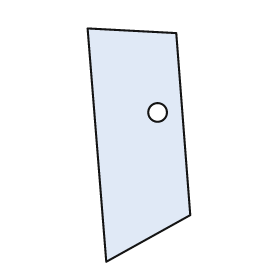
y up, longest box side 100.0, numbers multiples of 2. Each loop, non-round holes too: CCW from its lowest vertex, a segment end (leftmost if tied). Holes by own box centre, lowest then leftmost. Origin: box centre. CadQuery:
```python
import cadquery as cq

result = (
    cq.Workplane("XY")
    .moveTo(-14.0, -50.0)
    .lineTo(22.0, -30.0)
    .lineTo(16.0, 48.0)
    .lineTo(-22.0, 50.0)
    .close()
    .moveTo(8.0, 14.0)
    .circle(4.0)
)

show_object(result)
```